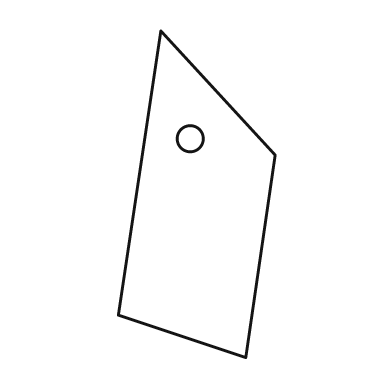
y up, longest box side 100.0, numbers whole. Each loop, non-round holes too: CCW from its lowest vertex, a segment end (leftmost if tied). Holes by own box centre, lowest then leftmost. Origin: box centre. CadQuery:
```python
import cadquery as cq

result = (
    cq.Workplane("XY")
    .moveTo(15.0, -50.0)
    .lineTo(24.0, 12.0)
    .lineTo(-11.0, 50.0)
    .lineTo(-24.0, -37.0)
    .close()
    .moveTo(-2.0, 17.0)
    .circle(4.0)
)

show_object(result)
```